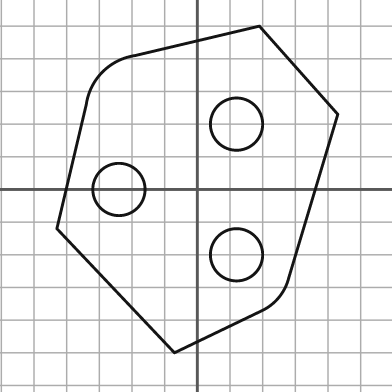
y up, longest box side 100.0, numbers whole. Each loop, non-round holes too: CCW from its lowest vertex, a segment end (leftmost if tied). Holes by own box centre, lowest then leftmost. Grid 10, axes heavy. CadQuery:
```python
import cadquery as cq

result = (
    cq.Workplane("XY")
    .moveTo(-7.0, -50.0)
    .lineTo(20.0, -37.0)
    .threePointArc((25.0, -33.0), (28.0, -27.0))
    .lineTo(43.0, 23.0)
    .lineTo(19.0, 50.0)
    .lineTo(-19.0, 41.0)
    .threePointArc((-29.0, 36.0), (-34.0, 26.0))
    .lineTo(-43.0, -12.0)
    .close()
    .moveTo(12.0, -20.0)
    .circle(8.0)
    .moveTo(-24.0, 0.0)
    .circle(8.0)
    .moveTo(12.0, 20.0)
    .circle(8.0)
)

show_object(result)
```